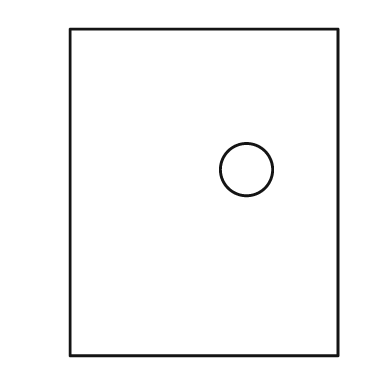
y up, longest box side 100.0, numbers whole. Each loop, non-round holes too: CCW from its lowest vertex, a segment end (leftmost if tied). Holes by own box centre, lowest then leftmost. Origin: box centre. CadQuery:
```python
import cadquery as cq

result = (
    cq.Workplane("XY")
    .moveTo(-41.0, -50.0)
    .lineTo(41.0, -50.0)
    .lineTo(41.0, 50.0)
    .lineTo(-41.0, 50.0)
    .close()
    .moveTo(13.0, 7.0)
    .circle(8.0)
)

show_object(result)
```